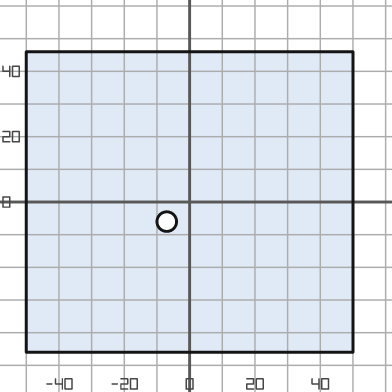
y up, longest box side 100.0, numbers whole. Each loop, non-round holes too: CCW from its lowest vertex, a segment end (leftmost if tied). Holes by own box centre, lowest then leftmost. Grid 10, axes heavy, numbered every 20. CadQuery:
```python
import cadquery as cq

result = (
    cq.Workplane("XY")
    .moveTo(-50.0, -46.0)
    .lineTo(50.0, -46.0)
    .lineTo(50.0, 46.0)
    .lineTo(-50.0, 46.0)
    .close()
    .moveTo(-7.0, -6.0)
    .circle(3.0)
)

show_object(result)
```